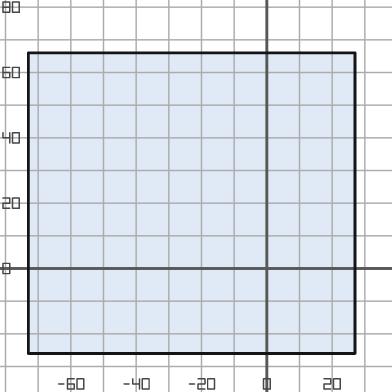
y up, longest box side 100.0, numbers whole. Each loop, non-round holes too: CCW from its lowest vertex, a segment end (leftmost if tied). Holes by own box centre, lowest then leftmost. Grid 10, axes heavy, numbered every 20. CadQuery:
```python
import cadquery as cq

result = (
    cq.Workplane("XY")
    .moveTo(-73.0, -26.0)
    .lineTo(27.0, -26.0)
    .lineTo(27.0, 66.0)
    .lineTo(-73.0, 66.0)
    .close()
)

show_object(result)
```